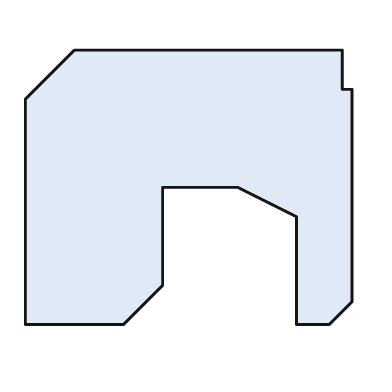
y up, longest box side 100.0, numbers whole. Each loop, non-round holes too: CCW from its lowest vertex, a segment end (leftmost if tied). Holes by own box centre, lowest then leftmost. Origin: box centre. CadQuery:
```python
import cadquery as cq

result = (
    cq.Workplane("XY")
    .moveTo(-50.0, -42.0)
    .lineTo(-20.0, -42.0)
    .lineTo(-8.0, -30.0)
    .lineTo(-8.0, 0.0)
    .lineTo(15.0, 0.0)
    .lineTo(33.0, -9.0)
    .lineTo(33.0, -42.0)
    .lineTo(43.0, -42.0)
    .lineTo(50.0, -35.0)
    .lineTo(50.0, 30.0)
    .lineTo(47.0, 30.0)
    .lineTo(47.0, 42.0)
    .lineTo(-35.0, 42.0)
    .lineTo(-50.0, 27.0)
    .close()
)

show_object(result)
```